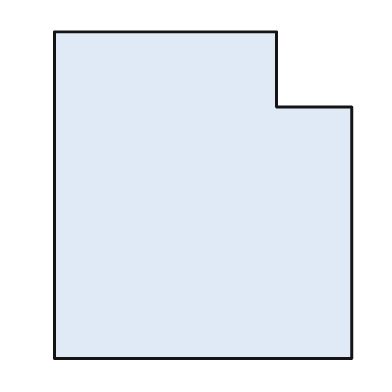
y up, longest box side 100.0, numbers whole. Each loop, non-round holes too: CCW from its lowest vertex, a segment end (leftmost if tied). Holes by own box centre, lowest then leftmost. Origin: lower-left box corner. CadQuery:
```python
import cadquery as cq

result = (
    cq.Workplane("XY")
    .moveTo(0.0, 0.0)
    .lineTo(91.0, 0.0)
    .lineTo(91.0, 77.0)
    .lineTo(68.0, 77.0)
    .lineTo(68.0, 100.0)
    .lineTo(0.0, 100.0)
    .close()
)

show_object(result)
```